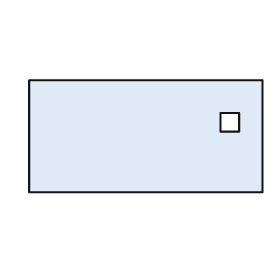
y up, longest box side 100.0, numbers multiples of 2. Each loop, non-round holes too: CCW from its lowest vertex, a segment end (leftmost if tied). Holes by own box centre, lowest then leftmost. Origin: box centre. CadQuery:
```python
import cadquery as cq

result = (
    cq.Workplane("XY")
    .moveTo(-50.0, -24.0)
    .lineTo(50.0, -24.0)
    .lineTo(50.0, 24.0)
    .lineTo(-50.0, 24.0)
    .close()
    .moveTo(32.0, 2.0)
    .lineTo(40.0, 2.0)
    .lineTo(40.0, 10.0)
    .lineTo(32.0, 10.0)
    .close()
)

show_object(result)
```